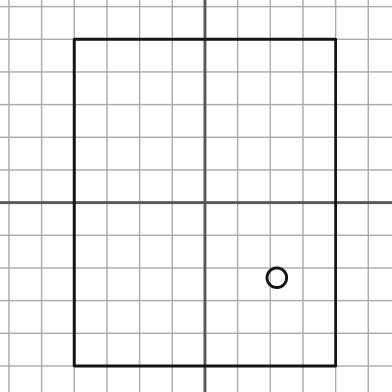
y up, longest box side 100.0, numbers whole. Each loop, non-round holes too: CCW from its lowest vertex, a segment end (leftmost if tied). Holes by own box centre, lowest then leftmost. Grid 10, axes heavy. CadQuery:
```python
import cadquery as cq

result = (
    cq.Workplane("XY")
    .moveTo(-40.0, -50.0)
    .lineTo(40.0, -50.0)
    .lineTo(40.0, 50.0)
    .lineTo(-40.0, 50.0)
    .close()
    .moveTo(22.0, -23.0)
    .circle(3.0)
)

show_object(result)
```